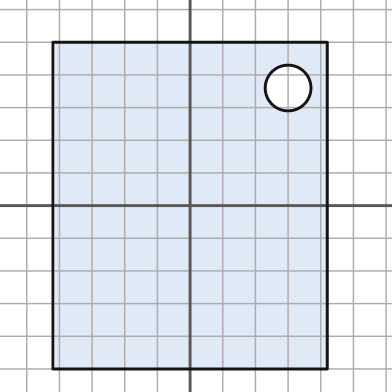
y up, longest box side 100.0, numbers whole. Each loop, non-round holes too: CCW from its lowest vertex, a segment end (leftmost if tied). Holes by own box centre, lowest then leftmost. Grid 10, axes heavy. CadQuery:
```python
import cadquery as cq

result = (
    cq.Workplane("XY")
    .moveTo(-42.0, -50.0)
    .lineTo(42.0, -50.0)
    .lineTo(42.0, 50.0)
    .lineTo(-42.0, 50.0)
    .close()
    .moveTo(30.0, 36.0)
    .circle(7.0)
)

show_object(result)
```